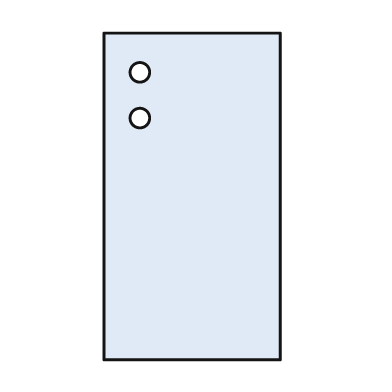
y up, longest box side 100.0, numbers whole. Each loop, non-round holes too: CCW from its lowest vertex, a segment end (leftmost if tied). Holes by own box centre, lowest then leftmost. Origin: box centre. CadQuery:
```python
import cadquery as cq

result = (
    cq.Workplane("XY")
    .moveTo(-27.0, -50.0)
    .lineTo(27.0, -50.0)
    .lineTo(27.0, 50.0)
    .lineTo(-27.0, 50.0)
    .close()
    .moveTo(-16.0, 24.0)
    .circle(3.0)
    .moveTo(-16.0, 38.0)
    .circle(3.0)
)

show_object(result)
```